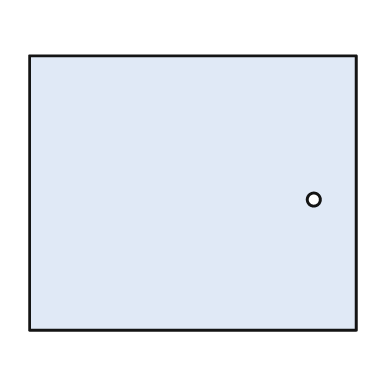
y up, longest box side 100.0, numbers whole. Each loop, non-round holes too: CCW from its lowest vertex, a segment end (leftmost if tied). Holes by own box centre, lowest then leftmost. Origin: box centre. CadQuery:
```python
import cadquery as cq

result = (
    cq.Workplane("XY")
    .moveTo(-50.0, -42.0)
    .lineTo(50.0, -42.0)
    .lineTo(50.0, 42.0)
    .lineTo(-50.0, 42.0)
    .close()
    .moveTo(37.0, -2.0)
    .circle(2.0)
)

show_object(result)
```